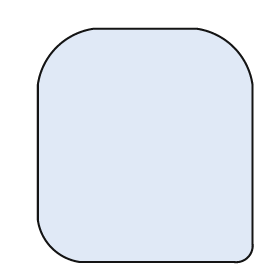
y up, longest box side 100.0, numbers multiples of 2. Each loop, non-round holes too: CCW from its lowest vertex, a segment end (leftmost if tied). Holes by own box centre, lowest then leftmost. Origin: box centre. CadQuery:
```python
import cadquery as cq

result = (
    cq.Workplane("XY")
    .moveTo(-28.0, -50.0)
    .lineTo(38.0, -50.0)
    .threePointArc((44.0, -48.0), (46.0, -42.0))
    .lineTo(46.0, 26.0)
    .threePointArc((38.0, 42.0), (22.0, 50.0))
    .lineTo(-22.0, 50.0)
    .threePointArc((-38.0, 42.0), (-46.0, 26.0))
    .lineTo(-46.0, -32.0)
    .threePointArc((-40.0, -44.0), (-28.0, -50.0))
    .close()
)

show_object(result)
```